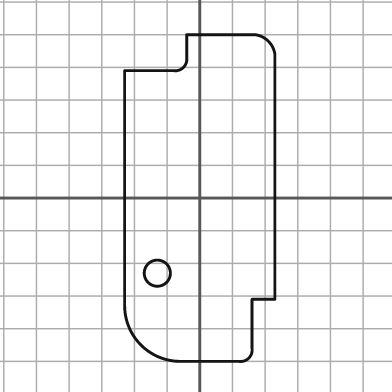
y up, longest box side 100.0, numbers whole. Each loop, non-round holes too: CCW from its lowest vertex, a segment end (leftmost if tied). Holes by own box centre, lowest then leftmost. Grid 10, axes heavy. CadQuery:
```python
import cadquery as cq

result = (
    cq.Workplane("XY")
    .moveTo(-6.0, -50.0)
    .lineTo(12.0, -50.0)
    .threePointArc((15.0, -49.0), (16.0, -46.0))
    .lineTo(16.0, -31.0)
    .lineTo(23.0, -31.0)
    .lineTo(23.0, 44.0)
    .threePointArc((21.0, 48.0), (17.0, 50.0))
    .lineTo(-4.0, 50.0)
    .lineTo(-4.0, 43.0)
    .threePointArc((-5.0, 40.0), (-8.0, 39.0))
    .lineTo(-23.0, 39.0)
    .lineTo(-23.0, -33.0)
    .threePointArc((-18.0, -45.0), (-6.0, -50.0))
    .close()
    .moveTo(-13.0, -23.0)
    .circle(4.0)
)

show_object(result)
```